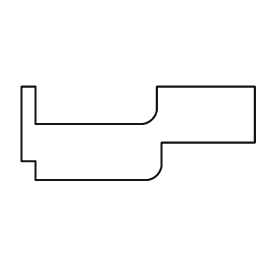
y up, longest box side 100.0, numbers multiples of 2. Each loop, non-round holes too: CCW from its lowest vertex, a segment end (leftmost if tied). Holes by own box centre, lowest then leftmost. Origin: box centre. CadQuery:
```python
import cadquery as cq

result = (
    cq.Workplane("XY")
    .moveTo(-44.0, -20.0)
    .lineTo(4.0, -20.0)
    .threePointArc((8.0, -18.0), (10.0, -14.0))
    .lineTo(10.0, -4.0)
    .lineTo(50.0, -4.0)
    .lineTo(50.0, 20.0)
    .lineTo(8.0, 20.0)
    .lineTo(8.0, 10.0)
    .threePointArc((6.0, 6.0), (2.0, 4.0))
    .lineTo(-44.0, 4.0)
    .lineTo(-44.0, 20.0)
    .lineTo(-50.0, 20.0)
    .lineTo(-50.0, -12.0)
    .lineTo(-44.0, -12.0)
    .close()
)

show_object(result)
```